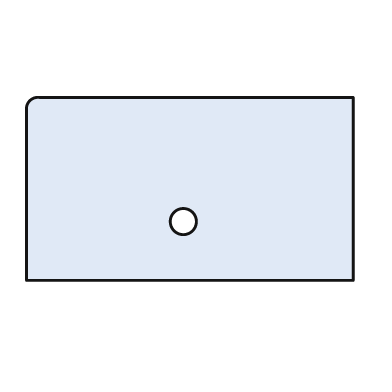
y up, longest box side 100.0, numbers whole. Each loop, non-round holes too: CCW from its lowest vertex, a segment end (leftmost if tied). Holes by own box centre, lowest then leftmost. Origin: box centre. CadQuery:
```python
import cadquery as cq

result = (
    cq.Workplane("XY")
    .moveTo(-50.0, -28.0)
    .lineTo(50.0, -28.0)
    .lineTo(50.0, 28.0)
    .lineTo(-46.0, 28.0)
    .threePointArc((-49.0, 27.0), (-50.0, 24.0))
    .close()
    .moveTo(-2.0, -10.0)
    .circle(4.0)
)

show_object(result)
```